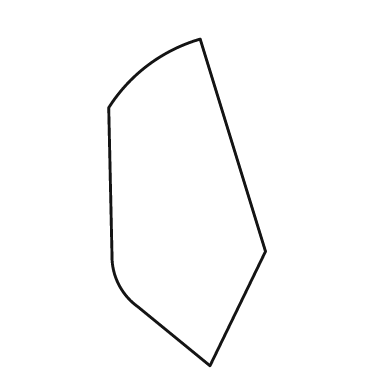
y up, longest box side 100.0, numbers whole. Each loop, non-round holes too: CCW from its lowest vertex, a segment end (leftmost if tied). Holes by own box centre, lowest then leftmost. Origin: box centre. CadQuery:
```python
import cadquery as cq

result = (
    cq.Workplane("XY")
    .moveTo(7.0, -50.0)
    .lineTo(24.0, -15.0)
    .lineTo(4.0, 50.0)
    .threePointArc((-12.0, 42.0), (-24.0, 29.0))
    .lineTo(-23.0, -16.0)
    .threePointArc((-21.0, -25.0), (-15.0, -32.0))
    .close()
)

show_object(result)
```